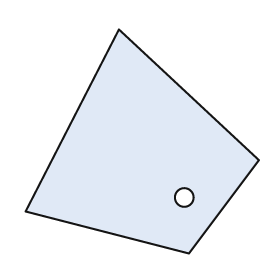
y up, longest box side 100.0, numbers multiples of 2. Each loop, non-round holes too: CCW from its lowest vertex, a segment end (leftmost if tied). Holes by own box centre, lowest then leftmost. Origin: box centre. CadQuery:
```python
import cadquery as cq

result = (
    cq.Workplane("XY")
    .moveTo(20.0, -48.0)
    .lineTo(50.0, -8.0)
    .lineTo(-10.0, 48.0)
    .lineTo(-50.0, -30.0)
    .close()
    .moveTo(18.0, -24.0)
    .circle(4.0)
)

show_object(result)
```